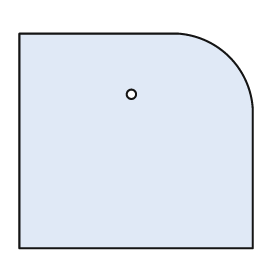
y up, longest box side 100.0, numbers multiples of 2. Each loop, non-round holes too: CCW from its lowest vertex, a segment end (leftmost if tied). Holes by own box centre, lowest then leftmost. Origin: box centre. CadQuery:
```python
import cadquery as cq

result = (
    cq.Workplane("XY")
    .moveTo(-50.0, -46.0)
    .lineTo(50.0, -46.0)
    .lineTo(50.0, 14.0)
    .threePointArc((40.0, 36.0), (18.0, 46.0))
    .lineTo(-50.0, 46.0)
    .close()
    .moveTo(-2.0, 20.0)
    .circle(2.0)
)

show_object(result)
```